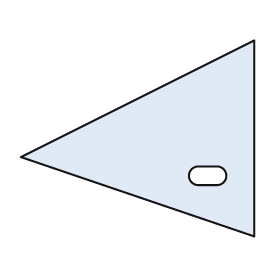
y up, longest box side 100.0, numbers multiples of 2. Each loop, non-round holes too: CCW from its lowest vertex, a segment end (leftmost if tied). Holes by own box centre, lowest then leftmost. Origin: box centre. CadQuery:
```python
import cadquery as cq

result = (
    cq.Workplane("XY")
    .moveTo(50.0, -42.0)
    .lineTo(50.0, 42.0)
    .lineTo(-50.0, -8.0)
    .close()
    .moveTo(26.0, -20.0)
    .lineTo(34.0, -20.0)
    .threePointArc((38.0, -16.0), (34.0, -12.0))
    .lineTo(26.0, -12.0)
    .threePointArc((22.0, -16.0), (26.0, -20.0))
    .close()
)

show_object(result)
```